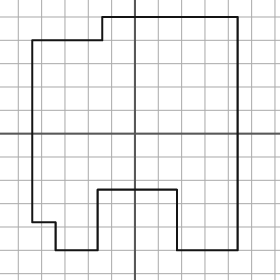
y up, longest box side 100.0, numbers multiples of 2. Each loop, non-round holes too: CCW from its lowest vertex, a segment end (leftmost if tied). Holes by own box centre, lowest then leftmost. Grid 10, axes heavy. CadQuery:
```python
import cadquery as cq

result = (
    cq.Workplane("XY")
    .moveTo(-34.0, -50.0)
    .lineTo(-16.0, -50.0)
    .lineTo(-16.0, -24.0)
    .lineTo(18.0, -24.0)
    .lineTo(18.0, -50.0)
    .lineTo(44.0, -50.0)
    .lineTo(44.0, 50.0)
    .lineTo(-14.0, 50.0)
    .lineTo(-14.0, 40.0)
    .lineTo(-44.0, 40.0)
    .lineTo(-44.0, -38.0)
    .lineTo(-34.0, -38.0)
    .close()
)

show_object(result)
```